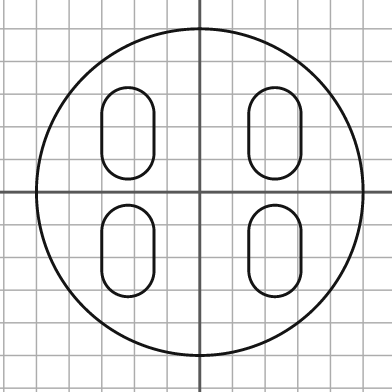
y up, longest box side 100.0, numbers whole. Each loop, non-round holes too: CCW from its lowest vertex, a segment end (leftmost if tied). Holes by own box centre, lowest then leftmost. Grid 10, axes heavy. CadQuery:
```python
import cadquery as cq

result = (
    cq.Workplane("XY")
    .moveTo(0.0, 0.0)
    .circle(50.0)
    .moveTo(-30.0, -24.0)
    .threePointArc((-22.0, -32.0), (-14.0, -24.0))
    .lineTo(-14.0, -12.0)
    .threePointArc((-22.0, -4.0), (-30.0, -12.0))
    .close()
    .moveTo(15.0, -24.0)
    .threePointArc((23.0, -32.0), (31.0, -24.0))
    .lineTo(31.0, -12.0)
    .threePointArc((23.0, -4.0), (15.0, -12.0))
    .close()
    .moveTo(-30.0, 12.0)
    .threePointArc((-22.0, 4.0), (-14.0, 12.0))
    .lineTo(-14.0, 24.0)
    .threePointArc((-22.0, 32.0), (-30.0, 24.0))
    .close()
    .moveTo(15.0, 12.0)
    .threePointArc((23.0, 4.0), (31.0, 12.0))
    .lineTo(31.0, 24.0)
    .threePointArc((23.0, 32.0), (15.0, 24.0))
    .close()
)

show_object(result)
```